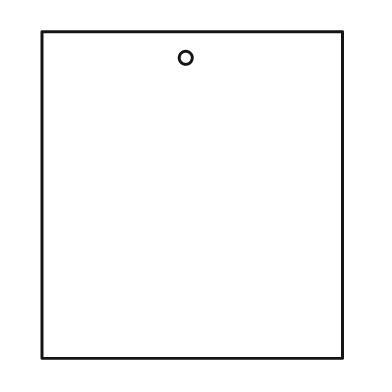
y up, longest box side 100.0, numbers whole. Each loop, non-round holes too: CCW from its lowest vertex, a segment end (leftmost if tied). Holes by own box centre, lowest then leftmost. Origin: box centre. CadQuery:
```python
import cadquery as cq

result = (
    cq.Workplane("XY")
    .moveTo(-46.0, -50.0)
    .lineTo(46.0, -50.0)
    .lineTo(46.0, 50.0)
    .lineTo(-46.0, 50.0)
    .close()
    .moveTo(-2.0, 42.0)
    .circle(2.0)
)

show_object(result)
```